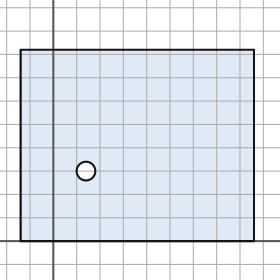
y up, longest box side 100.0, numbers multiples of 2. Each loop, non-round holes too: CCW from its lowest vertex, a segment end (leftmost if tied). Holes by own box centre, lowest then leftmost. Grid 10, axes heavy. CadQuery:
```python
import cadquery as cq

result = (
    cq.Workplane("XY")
    .moveTo(-14.0, 0.0)
    .lineTo(86.0, 0.0)
    .lineTo(86.0, 82.0)
    .lineTo(-14.0, 82.0)
    .close()
    .moveTo(14.0, 30.0)
    .circle(4.0)
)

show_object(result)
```